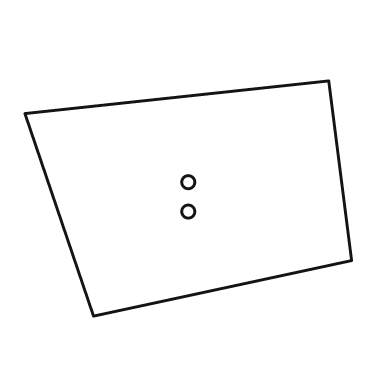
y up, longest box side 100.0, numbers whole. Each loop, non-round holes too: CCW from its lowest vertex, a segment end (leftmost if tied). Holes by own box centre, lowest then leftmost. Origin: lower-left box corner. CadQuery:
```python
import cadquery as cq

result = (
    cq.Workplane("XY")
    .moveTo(21.0, 0.0)
    .lineTo(100.0, 17.0)
    .lineTo(93.0, 72.0)
    .lineTo(0.0, 62.0)
    .close()
    .moveTo(50.0, 32.0)
    .circle(2.0)
    .moveTo(50.0, 41.0)
    .circle(2.0)
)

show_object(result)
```